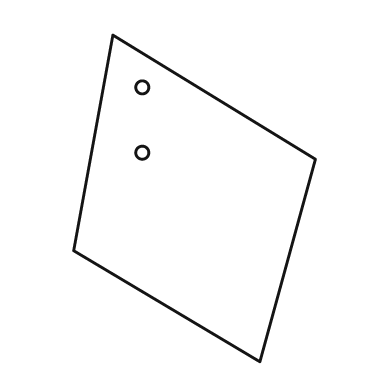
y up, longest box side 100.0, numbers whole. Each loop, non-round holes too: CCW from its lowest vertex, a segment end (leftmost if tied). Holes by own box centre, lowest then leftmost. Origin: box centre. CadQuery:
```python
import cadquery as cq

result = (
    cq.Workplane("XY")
    .moveTo(20.0, -50.0)
    .lineTo(37.0, 12.0)
    .lineTo(-25.0, 50.0)
    .lineTo(-37.0, -16.0)
    .close()
    .moveTo(-16.0, 14.0)
    .circle(2.0)
    .moveTo(-16.0, 34.0)
    .circle(2.0)
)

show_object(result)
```